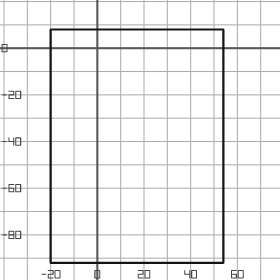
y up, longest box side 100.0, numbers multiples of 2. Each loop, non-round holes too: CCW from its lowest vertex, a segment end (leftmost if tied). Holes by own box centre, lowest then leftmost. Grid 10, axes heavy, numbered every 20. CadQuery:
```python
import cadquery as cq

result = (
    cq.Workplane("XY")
    .moveTo(-20.0, -92.0)
    .lineTo(54.0, -92.0)
    .lineTo(54.0, 8.0)
    .lineTo(-20.0, 8.0)
    .close()
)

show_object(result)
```